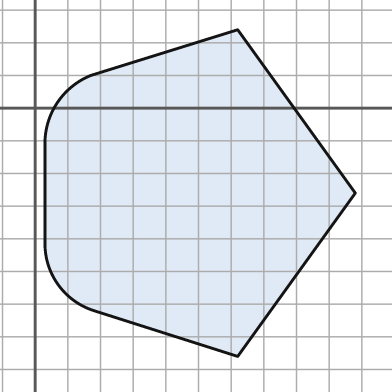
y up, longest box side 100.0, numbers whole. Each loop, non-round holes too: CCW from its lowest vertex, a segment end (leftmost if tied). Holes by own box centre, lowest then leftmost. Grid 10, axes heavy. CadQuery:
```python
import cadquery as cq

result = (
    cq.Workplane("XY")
    .moveTo(62.0, -76.0)
    .lineTo(98.0, -26.0)
    .lineTo(62.0, 24.0)
    .lineTo(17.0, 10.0)
    .threePointArc((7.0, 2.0), (3.0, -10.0))
    .lineTo(3.0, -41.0)
    .threePointArc((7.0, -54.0), (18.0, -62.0))
    .close()
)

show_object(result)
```